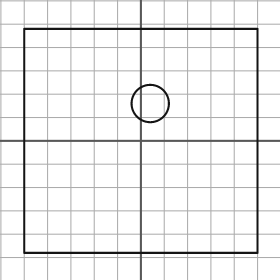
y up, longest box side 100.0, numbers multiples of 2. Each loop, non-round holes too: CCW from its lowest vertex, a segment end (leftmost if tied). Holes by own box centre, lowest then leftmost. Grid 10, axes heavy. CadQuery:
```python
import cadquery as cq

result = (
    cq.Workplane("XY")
    .moveTo(-50.0, -48.0)
    .lineTo(50.0, -48.0)
    .lineTo(50.0, 48.0)
    .lineTo(-50.0, 48.0)
    .close()
    .moveTo(4.0, 16.0)
    .circle(8.0)
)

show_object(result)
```